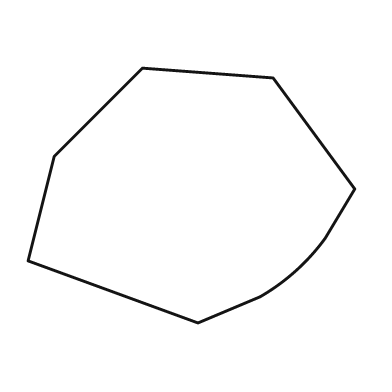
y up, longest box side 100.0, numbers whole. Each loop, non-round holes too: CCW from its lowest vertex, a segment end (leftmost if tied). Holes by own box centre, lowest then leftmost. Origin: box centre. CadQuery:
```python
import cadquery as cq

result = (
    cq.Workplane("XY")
    .moveTo(2.0, -39.0)
    .lineTo(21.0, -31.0)
    .threePointArc((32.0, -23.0), (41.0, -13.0))
    .lineTo(50.0, 2.0)
    .lineTo(25.0, 36.0)
    .lineTo(-15.0, 39.0)
    .lineTo(-42.0, 12.0)
    .lineTo(-50.0, -20.0)
    .close()
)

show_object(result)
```